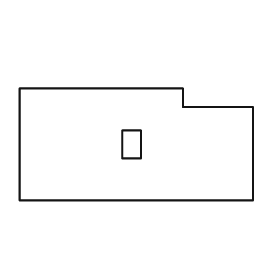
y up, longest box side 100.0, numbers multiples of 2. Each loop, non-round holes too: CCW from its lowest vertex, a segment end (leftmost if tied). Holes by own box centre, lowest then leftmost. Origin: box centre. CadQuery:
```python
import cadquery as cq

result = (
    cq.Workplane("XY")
    .moveTo(-50.0, -24.0)
    .lineTo(50.0, -24.0)
    .lineTo(50.0, 16.0)
    .lineTo(20.0, 16.0)
    .lineTo(20.0, 24.0)
    .lineTo(-50.0, 24.0)
    .close()
    .moveTo(-6.0, -6.0)
    .lineTo(2.0, -6.0)
    .lineTo(2.0, 6.0)
    .lineTo(-6.0, 6.0)
    .close()
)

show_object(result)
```